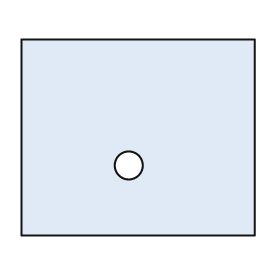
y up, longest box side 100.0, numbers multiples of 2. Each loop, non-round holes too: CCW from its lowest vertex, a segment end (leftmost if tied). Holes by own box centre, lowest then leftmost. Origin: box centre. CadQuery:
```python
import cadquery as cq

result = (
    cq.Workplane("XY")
    .moveTo(-50.0, -42.0)
    .lineTo(50.0, -42.0)
    .lineTo(50.0, 42.0)
    .lineTo(-50.0, 42.0)
    .close()
    .moveTo(-4.0, -12.0)
    .circle(6.0)
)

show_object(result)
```